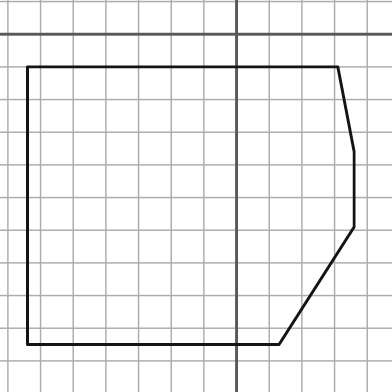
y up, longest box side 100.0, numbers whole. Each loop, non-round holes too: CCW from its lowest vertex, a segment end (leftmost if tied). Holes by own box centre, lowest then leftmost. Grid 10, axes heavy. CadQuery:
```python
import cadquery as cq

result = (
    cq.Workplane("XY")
    .moveTo(-64.0, -95.0)
    .lineTo(13.0, -95.0)
    .lineTo(36.0, -59.0)
    .lineTo(36.0, -36.0)
    .lineTo(31.0, -10.0)
    .lineTo(-64.0, -10.0)
    .close()
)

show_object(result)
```